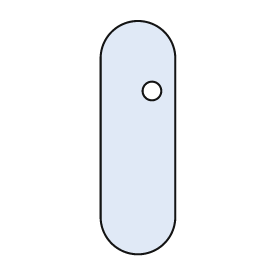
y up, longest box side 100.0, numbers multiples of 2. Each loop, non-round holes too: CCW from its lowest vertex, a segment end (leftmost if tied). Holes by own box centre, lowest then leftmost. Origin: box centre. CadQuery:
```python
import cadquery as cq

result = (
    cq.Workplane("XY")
    .moveTo(-16.0, -34.0)
    .threePointArc((0.0, -50.0), (16.0, -34.0))
    .lineTo(16.0, 34.0)
    .threePointArc((0.0, 50.0), (-16.0, 34.0))
    .close()
    .moveTo(6.0, 20.0)
    .circle(4.0)
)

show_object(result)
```